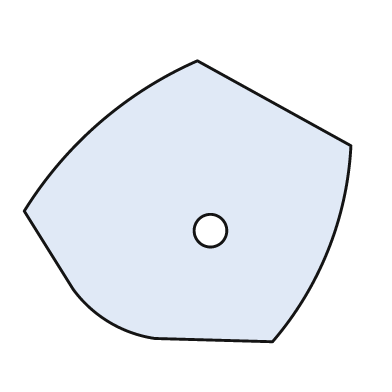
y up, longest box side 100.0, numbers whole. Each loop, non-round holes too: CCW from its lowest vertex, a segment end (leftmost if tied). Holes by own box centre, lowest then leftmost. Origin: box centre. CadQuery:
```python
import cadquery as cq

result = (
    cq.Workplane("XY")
    .moveTo(26.0, -43.0)
    .threePointArc((43.0, -15.0), (50.0, 17.0))
    .lineTo(3.0, 43.0)
    .threePointArc((-27.0, 24.0), (-50.0, -3.0))
    .lineTo(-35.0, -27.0)
    .threePointArc((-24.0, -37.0), (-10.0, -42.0))
    .close()
    .moveTo(7.0, -9.0)
    .circle(5.0)
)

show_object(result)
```